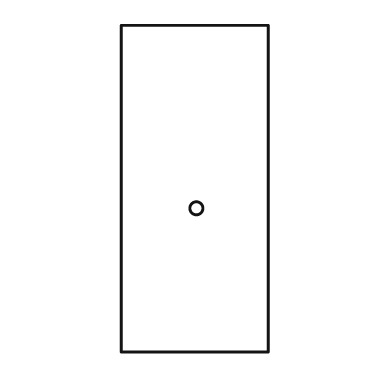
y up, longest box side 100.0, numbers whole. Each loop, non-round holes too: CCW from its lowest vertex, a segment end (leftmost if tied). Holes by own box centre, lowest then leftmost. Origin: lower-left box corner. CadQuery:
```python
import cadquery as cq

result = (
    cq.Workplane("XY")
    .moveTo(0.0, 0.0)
    .lineTo(45.0, 0.0)
    .lineTo(45.0, 100.0)
    .lineTo(0.0, 100.0)
    .close()
    .moveTo(23.0, 44.0)
    .circle(2.0)
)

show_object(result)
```